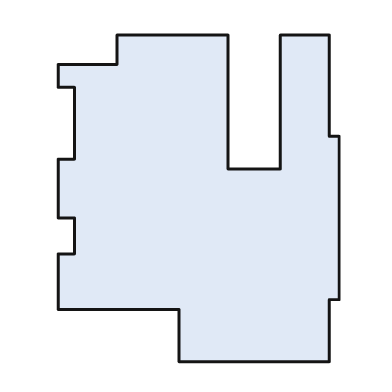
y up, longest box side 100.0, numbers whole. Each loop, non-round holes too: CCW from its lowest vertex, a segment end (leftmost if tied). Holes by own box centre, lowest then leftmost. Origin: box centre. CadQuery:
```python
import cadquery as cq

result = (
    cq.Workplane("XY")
    .moveTo(-6.0, -50.0)
    .lineTo(40.0, -50.0)
    .lineTo(40.0, -31.0)
    .lineTo(43.0, -31.0)
    .lineTo(43.0, 19.0)
    .lineTo(40.0, 19.0)
    .lineTo(40.0, 50.0)
    .lineTo(25.0, 50.0)
    .lineTo(25.0, 9.0)
    .lineTo(9.0, 9.0)
    .lineTo(9.0, 50.0)
    .lineTo(-25.0, 50.0)
    .lineTo(-25.0, 41.0)
    .lineTo(-43.0, 41.0)
    .lineTo(-43.0, 34.0)
    .lineTo(-38.0, 34.0)
    .lineTo(-38.0, 12.0)
    .lineTo(-43.0, 12.0)
    .lineTo(-43.0, -6.0)
    .lineTo(-38.0, -6.0)
    .lineTo(-38.0, -17.0)
    .lineTo(-43.0, -17.0)
    .lineTo(-43.0, -34.0)
    .lineTo(-6.0, -34.0)
    .close()
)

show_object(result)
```